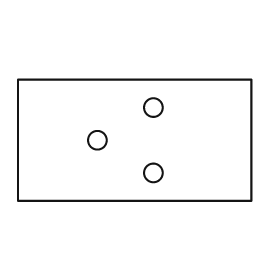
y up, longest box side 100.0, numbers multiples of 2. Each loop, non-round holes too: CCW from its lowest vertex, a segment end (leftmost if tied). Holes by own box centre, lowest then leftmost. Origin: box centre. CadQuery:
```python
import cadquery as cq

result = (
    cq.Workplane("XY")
    .moveTo(-50.0, -26.0)
    .lineTo(50.0, -26.0)
    .lineTo(50.0, 26.0)
    .lineTo(-50.0, 26.0)
    .close()
    .moveTo(8.0, -14.0)
    .circle(4.0)
    .moveTo(-16.0, 0.0)
    .circle(4.0)
    .moveTo(8.0, 14.0)
    .circle(4.0)
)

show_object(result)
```